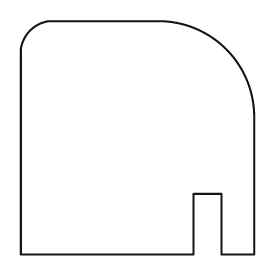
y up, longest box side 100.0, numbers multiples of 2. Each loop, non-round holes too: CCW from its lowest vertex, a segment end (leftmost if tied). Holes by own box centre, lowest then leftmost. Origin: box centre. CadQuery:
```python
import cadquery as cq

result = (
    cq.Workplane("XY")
    .moveTo(-50.0, -50.0)
    .lineTo(24.0, -50.0)
    .lineTo(24.0, -24.0)
    .lineTo(36.0, -24.0)
    .lineTo(36.0, -50.0)
    .lineTo(50.0, -50.0)
    .lineTo(50.0, 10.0)
    .threePointArc((38.0, 38.0), (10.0, 50.0))
    .lineTo(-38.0, 50.0)
    .threePointArc((-46.0, 46.0), (-50.0, 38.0))
    .close()
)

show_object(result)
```